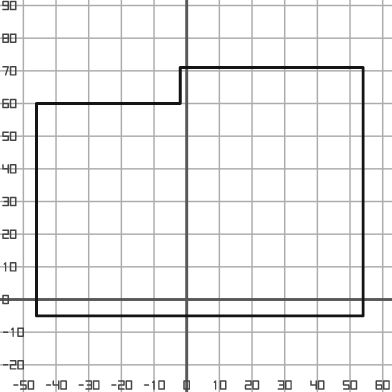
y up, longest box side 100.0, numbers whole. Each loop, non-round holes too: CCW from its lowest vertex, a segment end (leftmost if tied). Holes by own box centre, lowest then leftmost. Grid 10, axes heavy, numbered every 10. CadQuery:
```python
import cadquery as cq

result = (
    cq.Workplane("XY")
    .moveTo(-46.0, -5.0)
    .lineTo(54.0, -5.0)
    .lineTo(54.0, 71.0)
    .lineTo(-2.0, 71.0)
    .lineTo(-2.0, 60.0)
    .lineTo(-46.0, 60.0)
    .close()
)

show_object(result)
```